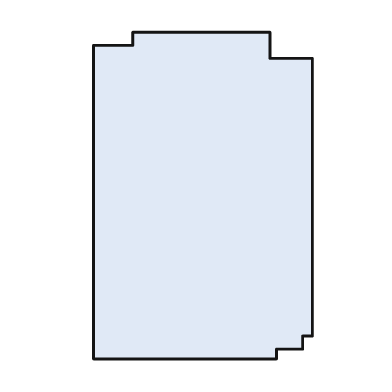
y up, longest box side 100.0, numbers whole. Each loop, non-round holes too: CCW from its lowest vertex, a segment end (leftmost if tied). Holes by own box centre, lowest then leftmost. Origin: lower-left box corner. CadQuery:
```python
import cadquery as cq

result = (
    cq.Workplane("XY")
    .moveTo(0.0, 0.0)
    .lineTo(56.0, 0.0)
    .lineTo(56.0, 3.0)
    .lineTo(64.0, 3.0)
    .lineTo(64.0, 7.0)
    .lineTo(67.0, 7.0)
    .lineTo(67.0, 92.0)
    .lineTo(54.0, 92.0)
    .lineTo(54.0, 100.0)
    .lineTo(12.0, 100.0)
    .lineTo(12.0, 96.0)
    .lineTo(0.0, 96.0)
    .close()
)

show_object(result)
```